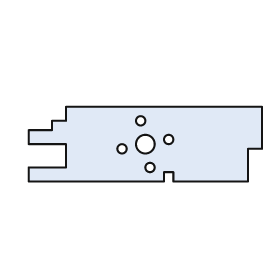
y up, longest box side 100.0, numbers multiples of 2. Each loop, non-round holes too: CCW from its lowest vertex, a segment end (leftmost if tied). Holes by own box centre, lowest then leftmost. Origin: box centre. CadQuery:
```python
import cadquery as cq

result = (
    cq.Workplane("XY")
    .moveTo(-50.0, -16.0)
    .lineTo(8.0, -16.0)
    .lineTo(8.0, -12.0)
    .lineTo(12.0, -12.0)
    .lineTo(12.0, -16.0)
    .lineTo(44.0, -16.0)
    .lineTo(44.0, -2.0)
    .lineTo(50.0, -2.0)
    .lineTo(50.0, 16.0)
    .lineTo(-34.0, 16.0)
    .lineTo(-34.0, 10.0)
    .lineTo(-40.0, 10.0)
    .lineTo(-40.0, 6.0)
    .lineTo(-50.0, 6.0)
    .lineTo(-50.0, 0.0)
    .lineTo(-34.0, 0.0)
    .lineTo(-34.0, -10.0)
    .lineTo(-50.0, -10.0)
    .close()
    .moveTo(2.0, -10.0)
    .circle(2.0)
    .moveTo(-10.0, -2.0)
    .circle(2.0)
    .moveTo(0.0, 0.0)
    .circle(4.0)
    .moveTo(10.0, 2.0)
    .circle(2.0)
    .moveTo(-2.0, 10.0)
    .circle(2.0)
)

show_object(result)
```